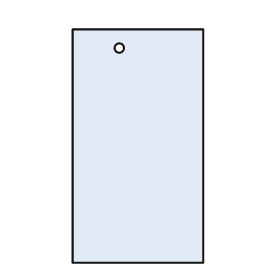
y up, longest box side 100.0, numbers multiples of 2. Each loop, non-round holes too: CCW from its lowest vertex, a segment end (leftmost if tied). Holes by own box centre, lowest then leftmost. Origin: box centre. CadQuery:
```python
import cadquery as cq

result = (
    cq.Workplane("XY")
    .moveTo(-28.0, -50.0)
    .lineTo(28.0, -50.0)
    .lineTo(28.0, 50.0)
    .lineTo(-28.0, 50.0)
    .close()
    .moveTo(-8.0, 42.0)
    .circle(2.0)
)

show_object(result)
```